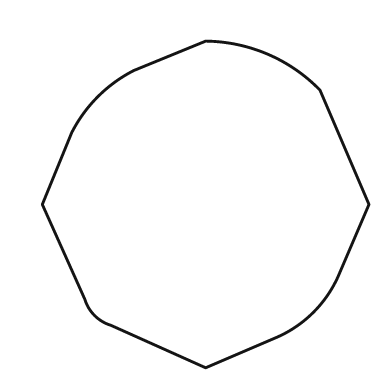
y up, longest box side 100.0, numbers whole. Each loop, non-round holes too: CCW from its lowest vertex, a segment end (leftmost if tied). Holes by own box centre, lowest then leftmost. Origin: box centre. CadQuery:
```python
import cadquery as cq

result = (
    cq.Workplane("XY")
    .moveTo(0.0, -50.0)
    .lineTo(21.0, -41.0)
    .threePointArc((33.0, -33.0), (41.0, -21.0))
    .lineTo(50.0, 0.0)
    .lineTo(35.0, 35.0)
    .threePointArc((19.0, 46.0), (0.0, 50.0))
    .lineTo(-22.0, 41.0)
    .threePointArc((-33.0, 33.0), (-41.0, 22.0))
    .lineTo(-50.0, 0.0)
    .lineTo(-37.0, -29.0)
    .threePointArc((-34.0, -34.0), (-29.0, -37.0))
    .close()
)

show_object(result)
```